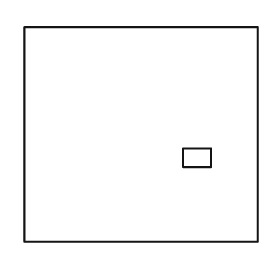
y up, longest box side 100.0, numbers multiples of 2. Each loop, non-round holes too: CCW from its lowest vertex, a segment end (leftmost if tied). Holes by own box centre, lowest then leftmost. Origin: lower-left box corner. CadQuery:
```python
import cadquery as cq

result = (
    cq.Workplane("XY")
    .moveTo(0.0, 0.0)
    .lineTo(100.0, 0.0)
    .lineTo(100.0, 92.0)
    .lineTo(0.0, 92.0)
    .close()
    .moveTo(68.0, 32.0)
    .lineTo(80.0, 32.0)
    .lineTo(80.0, 40.0)
    .lineTo(68.0, 40.0)
    .close()
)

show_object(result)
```